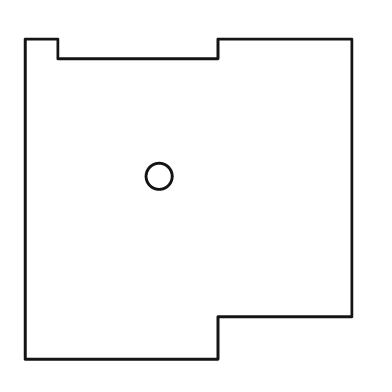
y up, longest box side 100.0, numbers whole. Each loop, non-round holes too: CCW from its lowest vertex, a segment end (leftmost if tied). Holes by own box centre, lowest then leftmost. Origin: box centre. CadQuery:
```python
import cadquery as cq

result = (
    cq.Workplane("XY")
    .moveTo(-50.0, -49.0)
    .lineTo(9.0, -49.0)
    .lineTo(9.0, -36.0)
    .lineTo(50.0, -36.0)
    .lineTo(50.0, 49.0)
    .lineTo(9.0, 49.0)
    .lineTo(9.0, 43.0)
    .lineTo(-40.0, 43.0)
    .lineTo(-40.0, 49.0)
    .lineTo(-50.0, 49.0)
    .close()
    .moveTo(-9.0, 7.0)
    .circle(4.0)
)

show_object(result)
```